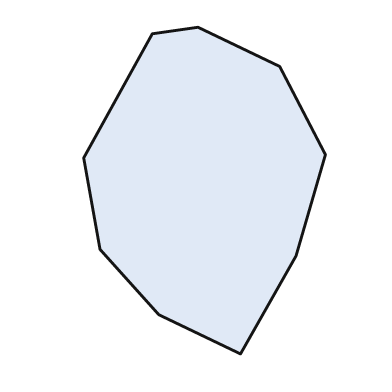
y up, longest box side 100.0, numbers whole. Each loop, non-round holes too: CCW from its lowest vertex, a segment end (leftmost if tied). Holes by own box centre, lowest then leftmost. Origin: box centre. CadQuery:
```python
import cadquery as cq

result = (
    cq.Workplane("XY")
    .moveTo(11.0, -50.0)
    .lineTo(28.0, -20.0)
    .lineTo(37.0, 11.0)
    .lineTo(23.0, 38.0)
    .lineTo(-2.0, 50.0)
    .lineTo(-16.0, 48.0)
    .lineTo(-37.0, 10.0)
    .lineTo(-32.0, -18.0)
    .lineTo(-14.0, -38.0)
    .close()
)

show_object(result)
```